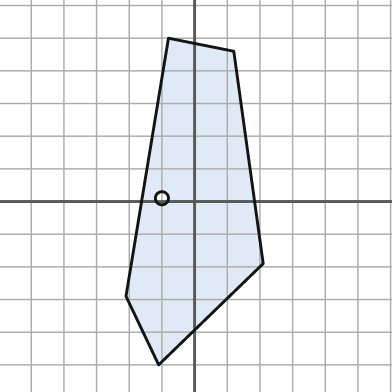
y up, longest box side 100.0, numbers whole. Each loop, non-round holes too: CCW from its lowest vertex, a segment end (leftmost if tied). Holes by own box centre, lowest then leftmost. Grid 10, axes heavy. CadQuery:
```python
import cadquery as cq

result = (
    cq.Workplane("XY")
    .moveTo(-11.0, -50.0)
    .lineTo(21.0, -19.0)
    .lineTo(12.0, 46.0)
    .lineTo(-8.0, 50.0)
    .lineTo(-21.0, -29.0)
    .close()
    .moveTo(-10.0, 1.0)
    .circle(2.0)
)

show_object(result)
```